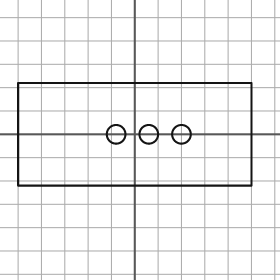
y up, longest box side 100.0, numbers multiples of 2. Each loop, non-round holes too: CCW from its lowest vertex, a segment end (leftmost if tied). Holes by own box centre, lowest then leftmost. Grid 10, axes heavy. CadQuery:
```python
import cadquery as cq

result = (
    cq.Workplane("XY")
    .moveTo(-50.0, -22.0)
    .lineTo(50.0, -22.0)
    .lineTo(50.0, 22.0)
    .lineTo(-50.0, 22.0)
    .close()
    .moveTo(-8.0, 0.0)
    .circle(4.0)
    .moveTo(6.0, 0.0)
    .circle(4.0)
    .moveTo(20.0, 0.0)
    .circle(4.0)
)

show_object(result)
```